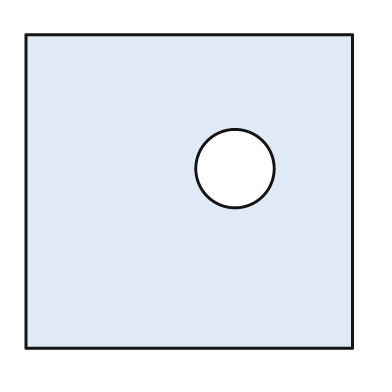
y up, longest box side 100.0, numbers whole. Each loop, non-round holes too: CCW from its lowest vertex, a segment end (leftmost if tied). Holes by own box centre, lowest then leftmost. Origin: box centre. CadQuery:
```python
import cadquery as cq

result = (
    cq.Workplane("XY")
    .moveTo(-50.0, -48.0)
    .lineTo(50.0, -48.0)
    .lineTo(50.0, 48.0)
    .lineTo(-50.0, 48.0)
    .close()
    .moveTo(14.0, 7.0)
    .circle(12.0)
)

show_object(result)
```